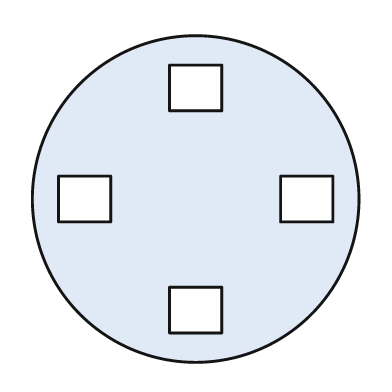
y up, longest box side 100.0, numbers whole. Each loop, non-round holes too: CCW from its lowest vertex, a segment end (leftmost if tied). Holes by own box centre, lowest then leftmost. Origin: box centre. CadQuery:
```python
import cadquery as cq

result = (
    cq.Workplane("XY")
    .moveTo(0.0, 0.0)
    .circle(50.0)
    .moveTo(-8.0, -41.0)
    .lineTo(8.0, -41.0)
    .lineTo(8.0, -27.0)
    .lineTo(-8.0, -27.0)
    .close()
    .moveTo(-42.0, -7.0)
    .lineTo(-26.0, -7.0)
    .lineTo(-26.0, 7.0)
    .lineTo(-42.0, 7.0)
    .close()
    .moveTo(26.0, -7.0)
    .lineTo(42.0, -7.0)
    .lineTo(42.0, 7.0)
    .lineTo(26.0, 7.0)
    .close()
    .moveTo(-8.0, 27.0)
    .lineTo(8.0, 27.0)
    .lineTo(8.0, 41.0)
    .lineTo(-8.0, 41.0)
    .close()
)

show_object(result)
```